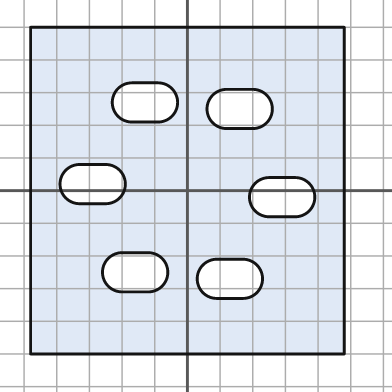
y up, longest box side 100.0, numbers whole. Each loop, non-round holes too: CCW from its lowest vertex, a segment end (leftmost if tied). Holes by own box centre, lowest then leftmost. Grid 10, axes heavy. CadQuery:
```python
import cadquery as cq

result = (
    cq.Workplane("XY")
    .moveTo(-48.0, -50.0)
    .lineTo(48.0, -50.0)
    .lineTo(48.0, 50.0)
    .lineTo(-48.0, 50.0)
    .close()
    .moveTo(9.0, -33.0)
    .lineTo(17.0, -33.0)
    .threePointArc((23.0, -27.0), (17.0, -21.0))
    .lineTo(9.0, -21.0)
    .threePointArc((3.0, -27.0), (9.0, -33.0))
    .close()
    .moveTo(-20.0, -31.0)
    .lineTo(-12.0, -31.0)
    .threePointArc((-6.0, -25.0), (-12.0, -19.0))
    .lineTo(-20.0, -19.0)
    .threePointArc((-26.0, -25.0), (-20.0, -31.0))
    .close()
    .moveTo(25.0, -8.0)
    .lineTo(33.0, -8.0)
    .threePointArc((39.0, -2.0), (33.0, 4.0))
    .lineTo(25.0, 4.0)
    .threePointArc((19.0, -2.0), (25.0, -8.0))
    .close()
    .moveTo(-33.0, -4.0)
    .lineTo(-25.0, -4.0)
    .threePointArc((-19.0, 2.0), (-25.0, 8.0))
    .lineTo(-33.0, 8.0)
    .threePointArc((-39.0, 2.0), (-33.0, -4.0))
    .close()
    .moveTo(12.0, 19.0)
    .lineTo(20.0, 19.0)
    .threePointArc((26.0, 25.0), (20.0, 31.0))
    .lineTo(12.0, 31.0)
    .threePointArc((6.0, 25.0), (12.0, 19.0))
    .close()
    .moveTo(-17.0, 21.0)
    .lineTo(-9.0, 21.0)
    .threePointArc((-3.0, 27.0), (-9.0, 33.0))
    .lineTo(-17.0, 33.0)
    .threePointArc((-23.0, 27.0), (-17.0, 21.0))
    .close()
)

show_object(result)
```